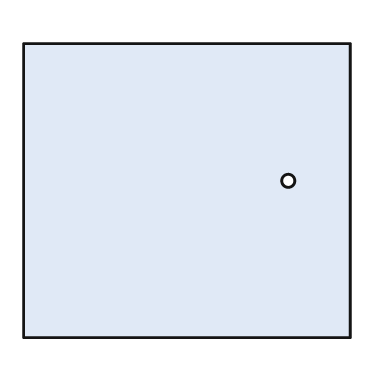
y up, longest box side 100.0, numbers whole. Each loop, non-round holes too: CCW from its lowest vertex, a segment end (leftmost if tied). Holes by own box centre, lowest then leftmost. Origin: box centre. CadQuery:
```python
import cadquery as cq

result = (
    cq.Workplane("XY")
    .moveTo(-50.0, -45.0)
    .lineTo(50.0, -45.0)
    .lineTo(50.0, 45.0)
    .lineTo(-50.0, 45.0)
    .close()
    .moveTo(31.0, 3.0)
    .circle(2.0)
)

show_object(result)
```